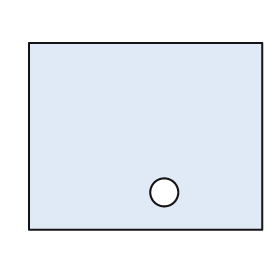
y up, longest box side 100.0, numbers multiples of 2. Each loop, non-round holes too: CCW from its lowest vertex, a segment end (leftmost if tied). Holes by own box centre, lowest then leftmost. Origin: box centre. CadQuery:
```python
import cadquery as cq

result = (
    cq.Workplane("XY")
    .moveTo(-50.0, -40.0)
    .lineTo(50.0, -40.0)
    .lineTo(50.0, 40.0)
    .lineTo(-50.0, 40.0)
    .close()
    .moveTo(8.0, -24.0)
    .circle(6.0)
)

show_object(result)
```